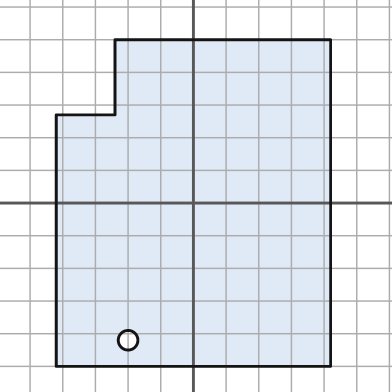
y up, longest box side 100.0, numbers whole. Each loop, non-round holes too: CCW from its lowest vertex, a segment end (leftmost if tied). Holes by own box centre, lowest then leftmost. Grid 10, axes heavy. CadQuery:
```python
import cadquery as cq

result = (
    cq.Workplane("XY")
    .moveTo(-42.0, -50.0)
    .lineTo(42.0, -50.0)
    .lineTo(42.0, 50.0)
    .lineTo(-24.0, 50.0)
    .lineTo(-24.0, 27.0)
    .lineTo(-42.0, 27.0)
    .close()
    .moveTo(-20.0, -42.0)
    .circle(3.0)
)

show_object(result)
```